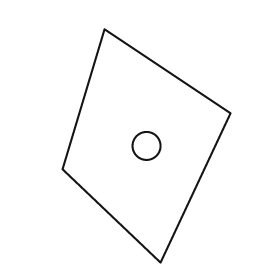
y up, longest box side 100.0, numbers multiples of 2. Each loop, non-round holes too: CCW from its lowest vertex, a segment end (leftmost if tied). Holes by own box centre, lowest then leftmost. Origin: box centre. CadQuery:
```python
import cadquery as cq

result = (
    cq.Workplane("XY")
    .moveTo(6.0, -50.0)
    .lineTo(36.0, 14.0)
    .lineTo(-18.0, 50.0)
    .lineTo(-36.0, -10.0)
    .close()
    .moveTo(0.0, 0.0)
    .circle(6.0)
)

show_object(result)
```